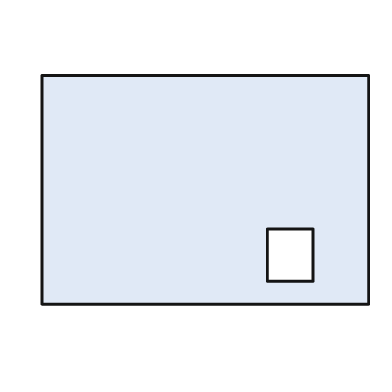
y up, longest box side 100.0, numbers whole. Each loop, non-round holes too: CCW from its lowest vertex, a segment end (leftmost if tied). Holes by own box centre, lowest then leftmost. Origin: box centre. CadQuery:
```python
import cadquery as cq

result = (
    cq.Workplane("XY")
    .moveTo(-50.0, -35.0)
    .lineTo(50.0, -35.0)
    .lineTo(50.0, 35.0)
    .lineTo(-50.0, 35.0)
    .close()
    .moveTo(19.0, -28.0)
    .lineTo(33.0, -28.0)
    .lineTo(33.0, -12.0)
    .lineTo(19.0, -12.0)
    .close()
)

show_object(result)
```